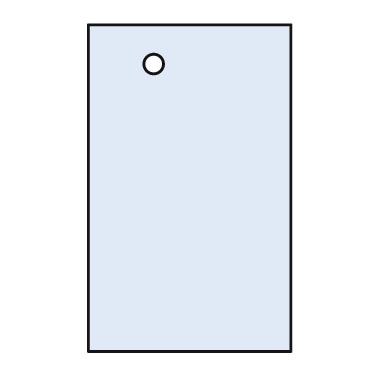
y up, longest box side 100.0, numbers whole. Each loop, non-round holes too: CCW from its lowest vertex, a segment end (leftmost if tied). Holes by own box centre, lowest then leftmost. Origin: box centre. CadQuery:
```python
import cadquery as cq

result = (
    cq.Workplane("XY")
    .moveTo(-31.0, -50.0)
    .lineTo(31.0, -50.0)
    .lineTo(31.0, 50.0)
    .lineTo(-31.0, 50.0)
    .close()
    .moveTo(-11.0, 38.0)
    .circle(3.0)
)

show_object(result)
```